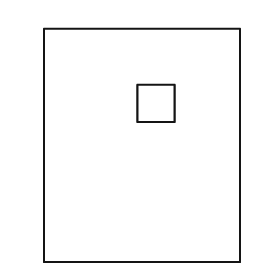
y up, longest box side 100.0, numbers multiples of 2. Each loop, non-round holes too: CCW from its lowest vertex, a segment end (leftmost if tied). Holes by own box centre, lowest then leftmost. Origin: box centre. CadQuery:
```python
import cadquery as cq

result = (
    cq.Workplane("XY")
    .moveTo(-42.0, -50.0)
    .lineTo(42.0, -50.0)
    .lineTo(42.0, 50.0)
    .lineTo(-42.0, 50.0)
    .close()
    .moveTo(-2.0, 10.0)
    .lineTo(14.0, 10.0)
    .lineTo(14.0, 26.0)
    .lineTo(-2.0, 26.0)
    .close()
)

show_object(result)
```